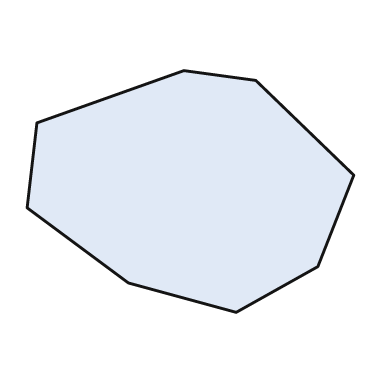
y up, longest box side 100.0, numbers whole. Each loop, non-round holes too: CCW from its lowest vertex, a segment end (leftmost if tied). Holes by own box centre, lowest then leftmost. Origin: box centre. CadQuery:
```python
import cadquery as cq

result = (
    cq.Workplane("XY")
    .moveTo(14.0, -37.0)
    .lineTo(39.0, -23.0)
    .lineTo(50.0, 5.0)
    .lineTo(20.0, 34.0)
    .lineTo(-2.0, 37.0)
    .lineTo(-47.0, 21.0)
    .lineTo(-50.0, -5.0)
    .lineTo(-19.0, -28.0)
    .close()
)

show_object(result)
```